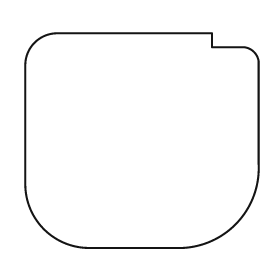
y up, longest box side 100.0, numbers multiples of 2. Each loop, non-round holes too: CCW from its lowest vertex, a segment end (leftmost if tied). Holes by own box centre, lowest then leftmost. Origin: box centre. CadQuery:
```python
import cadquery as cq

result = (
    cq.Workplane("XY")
    .moveTo(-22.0, -46.0)
    .lineTo(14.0, -46.0)
    .threePointArc((40.0, -36.0), (50.0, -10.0))
    .lineTo(50.0, 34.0)
    .threePointArc((48.0, 38.0), (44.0, 40.0))
    .lineTo(30.0, 40.0)
    .lineTo(30.0, 46.0)
    .lineTo(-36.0, 46.0)
    .threePointArc((-46.0, 42.0), (-50.0, 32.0))
    .lineTo(-50.0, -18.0)
    .threePointArc((-42.0, -38.0), (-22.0, -46.0))
    .close()
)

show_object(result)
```